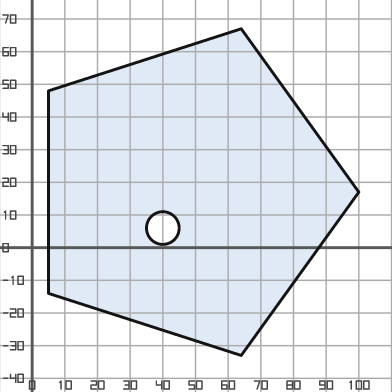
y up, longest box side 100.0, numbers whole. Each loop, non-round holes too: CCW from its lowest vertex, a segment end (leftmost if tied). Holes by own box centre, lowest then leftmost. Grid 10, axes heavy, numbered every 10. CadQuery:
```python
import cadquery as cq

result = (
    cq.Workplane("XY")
    .moveTo(64.0, -33.0)
    .lineTo(100.0, 17.0)
    .lineTo(64.0, 67.0)
    .lineTo(5.0, 48.0)
    .lineTo(5.0, -14.0)
    .close()
    .moveTo(40.0, 6.0)
    .circle(5.0)
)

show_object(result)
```